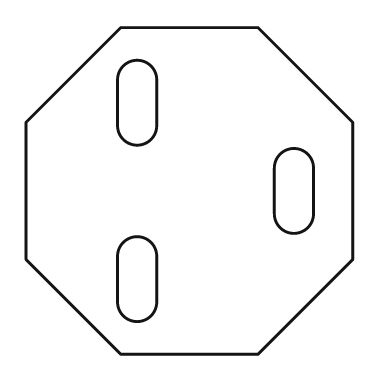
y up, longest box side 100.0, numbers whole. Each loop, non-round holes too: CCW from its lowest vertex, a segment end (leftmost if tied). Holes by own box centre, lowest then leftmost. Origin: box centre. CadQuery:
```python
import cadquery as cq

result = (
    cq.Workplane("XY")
    .moveTo(-21.0, -50.0)
    .lineTo(21.0, -50.0)
    .lineTo(50.0, -21.0)
    .lineTo(50.0, 21.0)
    .lineTo(21.0, 50.0)
    .lineTo(-21.0, 50.0)
    .lineTo(-50.0, 21.0)
    .lineTo(-50.0, -21.0)
    .close()
    .moveTo(-22.0, -34.0)
    .threePointArc((-16.0, -40.0), (-10.0, -34.0))
    .lineTo(-10.0, -20.0)
    .threePointArc((-16.0, -14.0), (-22.0, -20.0))
    .close()
    .moveTo(26.0, -7.0)
    .threePointArc((32.0, -13.0), (38.0, -7.0))
    .lineTo(38.0, 7.0)
    .threePointArc((32.0, 13.0), (26.0, 7.0))
    .close()
    .moveTo(-22.0, 20.0)
    .threePointArc((-16.0, 14.0), (-10.0, 20.0))
    .lineTo(-10.0, 34.0)
    .threePointArc((-16.0, 40.0), (-22.0, 34.0))
    .close()
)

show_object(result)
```